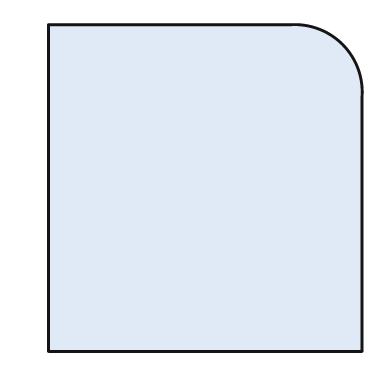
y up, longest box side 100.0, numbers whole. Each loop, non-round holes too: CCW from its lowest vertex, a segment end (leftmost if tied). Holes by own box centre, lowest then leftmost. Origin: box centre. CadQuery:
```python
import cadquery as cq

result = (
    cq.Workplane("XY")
    .moveTo(-48.0, -50.0)
    .lineTo(48.0, -50.0)
    .lineTo(48.0, 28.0)
    .threePointArc((42.0, 44.0), (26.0, 50.0))
    .lineTo(-48.0, 50.0)
    .close()
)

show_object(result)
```